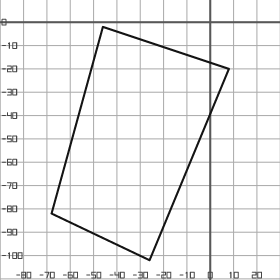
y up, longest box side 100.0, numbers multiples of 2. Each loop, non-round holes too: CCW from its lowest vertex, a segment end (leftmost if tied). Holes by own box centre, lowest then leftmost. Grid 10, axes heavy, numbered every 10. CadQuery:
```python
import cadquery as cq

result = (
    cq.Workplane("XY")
    .moveTo(-26.0, -102.0)
    .lineTo(8.0, -20.0)
    .lineTo(-46.0, -2.0)
    .lineTo(-68.0, -82.0)
    .close()
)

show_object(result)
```